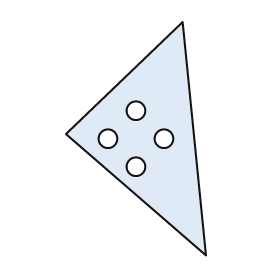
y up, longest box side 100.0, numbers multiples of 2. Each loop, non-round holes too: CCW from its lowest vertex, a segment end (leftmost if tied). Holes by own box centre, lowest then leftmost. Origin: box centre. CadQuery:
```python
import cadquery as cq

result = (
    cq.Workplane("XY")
    .moveTo(30.0, -50.0)
    .lineTo(20.0, 50.0)
    .lineTo(-30.0, 2.0)
    .close()
    .moveTo(0.0, -12.0)
    .circle(4.0)
    .moveTo(-12.0, 0.0)
    .circle(4.0)
    .moveTo(12.0, 0.0)
    .circle(4.0)
    .moveTo(0.0, 12.0)
    .circle(4.0)
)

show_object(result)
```